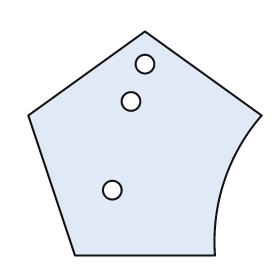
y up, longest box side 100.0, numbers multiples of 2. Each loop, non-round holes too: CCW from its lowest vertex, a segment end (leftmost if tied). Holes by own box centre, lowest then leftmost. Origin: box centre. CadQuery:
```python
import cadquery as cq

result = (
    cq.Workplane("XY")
    .moveTo(-30.0, -48.0)
    .lineTo(30.0, -48.0)
    .threePointArc((34.0, -16.0), (50.0, 12.0))
    .lineTo(0.0, 48.0)
    .lineTo(-50.0, 12.0)
    .close()
    .moveTo(-14.0, -20.0)
    .circle(4.0)
    .moveTo(-6.0, 18.0)
    .circle(4.0)
    .moveTo(0.0, 34.0)
    .circle(4.0)
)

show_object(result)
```